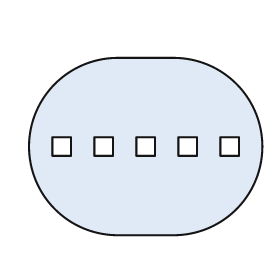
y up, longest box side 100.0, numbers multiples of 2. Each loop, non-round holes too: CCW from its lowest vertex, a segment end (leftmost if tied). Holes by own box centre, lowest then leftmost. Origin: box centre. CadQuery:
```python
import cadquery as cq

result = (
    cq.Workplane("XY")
    .moveTo(-12.0, -38.0)
    .lineTo(12.0, -38.0)
    .threePointArc((50.0, 0.0), (12.0, 38.0))
    .lineTo(-12.0, 38.0)
    .threePointArc((-50.0, 0.0), (-12.0, -38.0))
    .close()
    .moveTo(-40.0, -4.0)
    .lineTo(-32.0, -4.0)
    .lineTo(-32.0, 4.0)
    .lineTo(-40.0, 4.0)
    .close()
    .moveTo(-22.0, -4.0)
    .lineTo(-14.0, -4.0)
    .lineTo(-14.0, 4.0)
    .lineTo(-22.0, 4.0)
    .close()
    .moveTo(-4.0, -4.0)
    .lineTo(4.0, -4.0)
    .lineTo(4.0, 4.0)
    .lineTo(-4.0, 4.0)
    .close()
    .moveTo(14.0, -4.0)
    .lineTo(22.0, -4.0)
    .lineTo(22.0, 4.0)
    .lineTo(14.0, 4.0)
    .close()
    .moveTo(32.0, -4.0)
    .lineTo(40.0, -4.0)
    .lineTo(40.0, 4.0)
    .lineTo(32.0, 4.0)
    .close()
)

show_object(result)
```